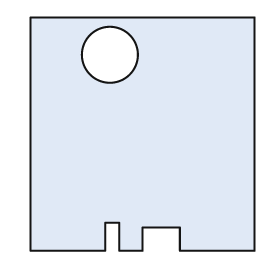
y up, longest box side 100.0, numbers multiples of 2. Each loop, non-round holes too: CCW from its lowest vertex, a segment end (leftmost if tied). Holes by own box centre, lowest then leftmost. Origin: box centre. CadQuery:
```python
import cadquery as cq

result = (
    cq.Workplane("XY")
    .moveTo(-48.0, -50.0)
    .lineTo(-16.0, -50.0)
    .lineTo(-16.0, -38.0)
    .lineTo(-10.0, -38.0)
    .lineTo(-10.0, -50.0)
    .lineTo(0.0, -50.0)
    .lineTo(0.0, -40.0)
    .lineTo(16.0, -40.0)
    .lineTo(16.0, -50.0)
    .lineTo(48.0, -50.0)
    .lineTo(48.0, 50.0)
    .lineTo(-48.0, 50.0)
    .close()
    .moveTo(-14.0, 34.0)
    .circle(12.0)
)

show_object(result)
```